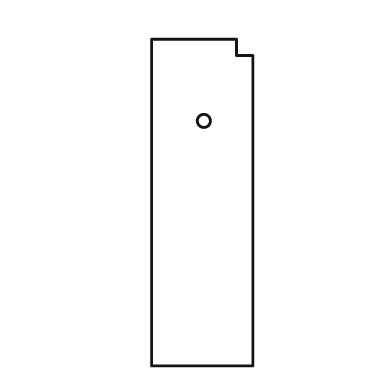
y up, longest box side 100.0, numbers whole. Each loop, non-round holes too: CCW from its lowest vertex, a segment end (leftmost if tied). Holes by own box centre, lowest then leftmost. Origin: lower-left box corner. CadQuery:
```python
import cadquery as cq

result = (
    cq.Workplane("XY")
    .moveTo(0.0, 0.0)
    .lineTo(31.0, 0.0)
    .lineTo(31.0, 95.0)
    .lineTo(26.0, 95.0)
    .lineTo(26.0, 100.0)
    .lineTo(0.0, 100.0)
    .close()
    .moveTo(16.0, 75.0)
    .circle(2.0)
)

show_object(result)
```